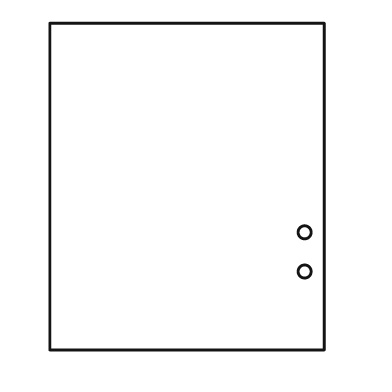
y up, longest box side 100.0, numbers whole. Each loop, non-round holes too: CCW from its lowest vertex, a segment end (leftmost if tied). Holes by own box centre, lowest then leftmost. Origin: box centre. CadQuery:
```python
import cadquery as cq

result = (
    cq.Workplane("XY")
    .moveTo(-42.0, -50.0)
    .lineTo(42.0, -50.0)
    .lineTo(42.0, 50.0)
    .lineTo(-42.0, 50.0)
    .close()
    .moveTo(36.0, -26.0)
    .circle(2.0)
    .moveTo(36.0, -14.0)
    .circle(2.0)
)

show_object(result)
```